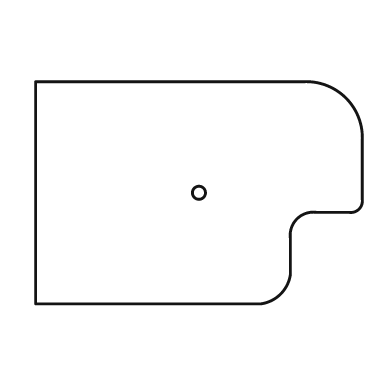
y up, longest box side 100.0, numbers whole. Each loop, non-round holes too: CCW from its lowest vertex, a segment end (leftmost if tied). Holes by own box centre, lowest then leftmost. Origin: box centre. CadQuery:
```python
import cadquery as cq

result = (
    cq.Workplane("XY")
    .moveTo(-50.0, -34.0)
    .lineTo(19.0, -34.0)
    .threePointArc((25.0, -31.0), (28.0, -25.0))
    .lineTo(28.0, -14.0)
    .threePointArc((30.0, -8.0), (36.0, -6.0))
    .lineTo(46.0, -6.0)
    .threePointArc((49.0, -5.0), (50.0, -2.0))
    .lineTo(50.0, 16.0)
    .threePointArc((45.0, 29.0), (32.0, 34.0))
    .lineTo(-50.0, 34.0)
    .close()
    .moveTo(0.0, 0.0)
    .circle(2.0)
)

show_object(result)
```